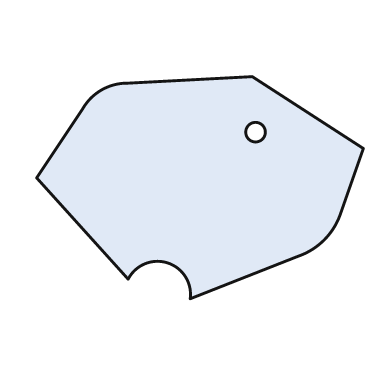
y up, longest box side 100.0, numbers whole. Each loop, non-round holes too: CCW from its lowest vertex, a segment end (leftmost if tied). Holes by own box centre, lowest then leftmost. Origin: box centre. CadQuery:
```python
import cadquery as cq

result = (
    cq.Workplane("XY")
    .moveTo(-3.0, -34.0)
    .lineTo(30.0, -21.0)
    .threePointArc((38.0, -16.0), (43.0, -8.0))
    .lineTo(50.0, 12.0)
    .lineTo(16.0, 34.0)
    .lineTo(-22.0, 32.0)
    .threePointArc((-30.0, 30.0), (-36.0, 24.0))
    .lineTo(-50.0, 3.0)
    .lineTo(-22.0, -28.0)
    .threePointArc((-10.0, -23.0), (-3.0, -34.0))
    .close()
    .moveTo(17.0, 17.0)
    .circle(3.0)
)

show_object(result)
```